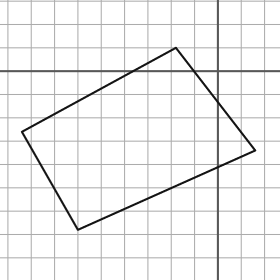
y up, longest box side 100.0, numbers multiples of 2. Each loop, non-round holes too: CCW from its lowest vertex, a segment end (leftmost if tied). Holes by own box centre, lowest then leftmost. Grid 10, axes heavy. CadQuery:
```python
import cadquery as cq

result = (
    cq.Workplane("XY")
    .moveTo(-60.0, -68.0)
    .lineTo(16.0, -34.0)
    .lineTo(-18.0, 10.0)
    .lineTo(-84.0, -26.0)
    .close()
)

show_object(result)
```